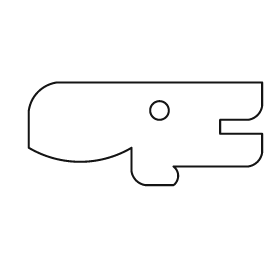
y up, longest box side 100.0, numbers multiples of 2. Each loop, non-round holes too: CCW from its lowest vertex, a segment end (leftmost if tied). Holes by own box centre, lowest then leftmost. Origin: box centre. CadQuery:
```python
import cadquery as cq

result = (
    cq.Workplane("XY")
    .moveTo(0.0, -22.0)
    .lineTo(12.0, -22.0)
    .threePointArc((14.0, -18.0), (12.0, -14.0))
    .lineTo(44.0, -14.0)
    .threePointArc((48.0, -12.0), (50.0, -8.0))
    .lineTo(50.0, 0.0)
    .lineTo(32.0, 0.0)
    .lineTo(32.0, 6.0)
    .lineTo(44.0, 6.0)
    .threePointArc((48.0, 8.0), (50.0, 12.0))
    .lineTo(50.0, 22.0)
    .lineTo(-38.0, 22.0)
    .threePointArc((-46.0, 18.0), (-50.0, 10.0))
    .lineTo(-50.0, -6.0)
    .threePointArc((-28.0, -12.0), (-6.0, -6.0))
    .lineTo(-6.0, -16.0)
    .threePointArc((-4.0, -20.0), (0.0, -22.0))
    .close()
    .moveTo(6.0, 10.0)
    .circle(4.0)
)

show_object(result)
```